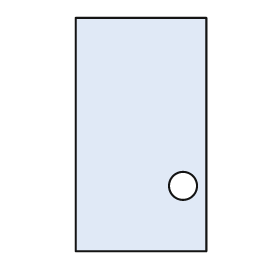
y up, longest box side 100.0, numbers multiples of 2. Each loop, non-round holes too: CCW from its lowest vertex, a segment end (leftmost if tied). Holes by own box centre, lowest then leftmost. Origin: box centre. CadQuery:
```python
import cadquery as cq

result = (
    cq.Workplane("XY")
    .moveTo(-28.0, -50.0)
    .lineTo(28.0, -50.0)
    .lineTo(28.0, 50.0)
    .lineTo(-28.0, 50.0)
    .close()
    .moveTo(18.0, -22.0)
    .circle(6.0)
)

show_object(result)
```